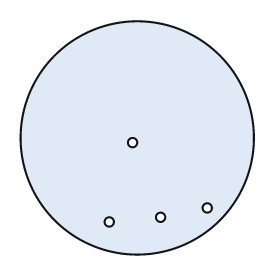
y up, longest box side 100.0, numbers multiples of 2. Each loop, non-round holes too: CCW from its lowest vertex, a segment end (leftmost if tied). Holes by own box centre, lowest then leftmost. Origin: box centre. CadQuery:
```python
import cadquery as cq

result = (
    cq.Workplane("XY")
    .moveTo(0.0, 0.0)
    .circle(50.0)
    .moveTo(-12.0, -36.0)
    .circle(2.0)
    .moveTo(10.0, -34.0)
    .circle(2.0)
    .moveTo(30.0, -30.0)
    .circle(2.0)
    .moveTo(-2.0, -2.0)
    .circle(2.0)
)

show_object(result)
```